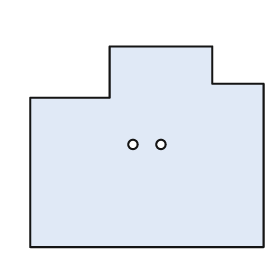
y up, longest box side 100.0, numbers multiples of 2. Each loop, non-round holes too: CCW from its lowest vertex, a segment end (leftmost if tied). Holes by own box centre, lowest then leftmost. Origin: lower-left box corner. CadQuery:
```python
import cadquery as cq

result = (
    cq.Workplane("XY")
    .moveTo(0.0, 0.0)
    .lineTo(100.0, 0.0)
    .lineTo(100.0, 70.0)
    .lineTo(78.0, 70.0)
    .lineTo(78.0, 86.0)
    .lineTo(34.0, 86.0)
    .lineTo(34.0, 64.0)
    .lineTo(0.0, 64.0)
    .close()
    .moveTo(44.0, 44.0)
    .circle(2.0)
    .moveTo(56.0, 44.0)
    .circle(2.0)
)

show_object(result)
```